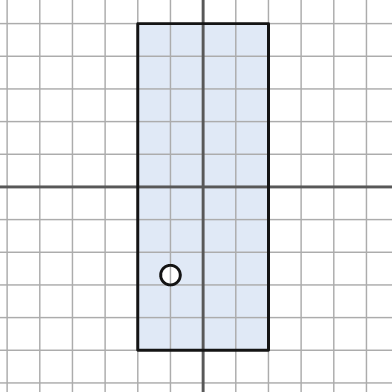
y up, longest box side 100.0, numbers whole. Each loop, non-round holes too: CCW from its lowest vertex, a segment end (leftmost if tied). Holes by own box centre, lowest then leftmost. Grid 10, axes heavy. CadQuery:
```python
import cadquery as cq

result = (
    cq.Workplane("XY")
    .moveTo(-20.0, -50.0)
    .lineTo(20.0, -50.0)
    .lineTo(20.0, 50.0)
    .lineTo(-20.0, 50.0)
    .close()
    .moveTo(-10.0, -27.0)
    .circle(3.0)
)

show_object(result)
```